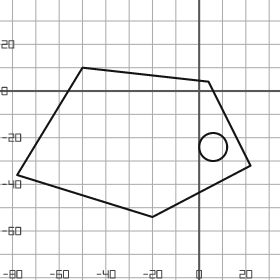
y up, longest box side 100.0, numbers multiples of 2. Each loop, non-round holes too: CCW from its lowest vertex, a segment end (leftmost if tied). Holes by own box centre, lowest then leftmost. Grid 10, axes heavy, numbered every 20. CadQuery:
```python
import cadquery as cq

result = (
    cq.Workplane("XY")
    .moveTo(-20.0, -54.0)
    .lineTo(22.0, -32.0)
    .lineTo(4.0, 4.0)
    .lineTo(-50.0, 10.0)
    .lineTo(-78.0, -36.0)
    .close()
    .moveTo(6.0, -24.0)
    .circle(6.0)
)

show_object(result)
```